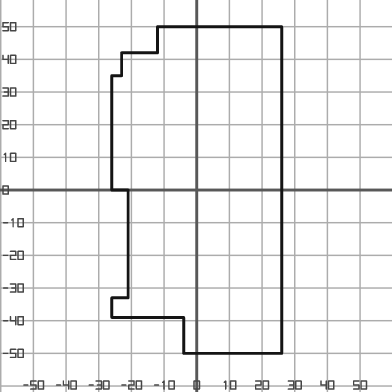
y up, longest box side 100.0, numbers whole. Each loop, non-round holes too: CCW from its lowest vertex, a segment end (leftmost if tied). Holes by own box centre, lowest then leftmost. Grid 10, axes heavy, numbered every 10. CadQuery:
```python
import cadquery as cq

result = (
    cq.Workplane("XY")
    .moveTo(-4.0, -50.0)
    .lineTo(26.0, -50.0)
    .lineTo(26.0, 50.0)
    .lineTo(-12.0, 50.0)
    .lineTo(-12.0, 42.0)
    .lineTo(-23.0, 42.0)
    .lineTo(-23.0, 35.0)
    .lineTo(-26.0, 35.0)
    .lineTo(-26.0, 0.0)
    .lineTo(-21.0, 0.0)
    .lineTo(-21.0, -33.0)
    .lineTo(-26.0, -33.0)
    .lineTo(-26.0, -39.0)
    .lineTo(-4.0, -39.0)
    .close()
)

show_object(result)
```